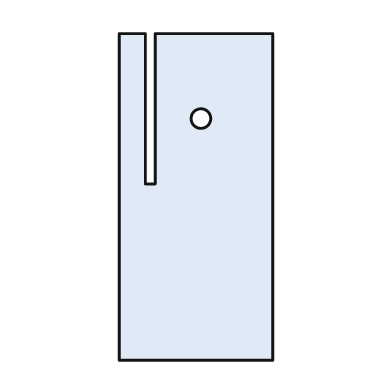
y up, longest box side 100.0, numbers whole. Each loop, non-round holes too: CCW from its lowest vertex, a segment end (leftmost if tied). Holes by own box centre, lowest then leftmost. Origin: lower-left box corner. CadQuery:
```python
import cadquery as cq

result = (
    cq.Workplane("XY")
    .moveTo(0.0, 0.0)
    .lineTo(47.0, 0.0)
    .lineTo(47.0, 100.0)
    .lineTo(11.0, 100.0)
    .lineTo(11.0, 54.0)
    .lineTo(8.0, 54.0)
    .lineTo(8.0, 100.0)
    .lineTo(0.0, 100.0)
    .close()
    .moveTo(25.0, 74.0)
    .circle(3.0)
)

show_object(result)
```